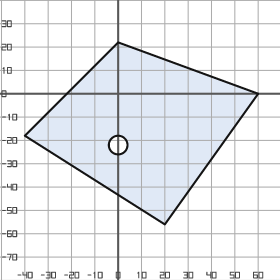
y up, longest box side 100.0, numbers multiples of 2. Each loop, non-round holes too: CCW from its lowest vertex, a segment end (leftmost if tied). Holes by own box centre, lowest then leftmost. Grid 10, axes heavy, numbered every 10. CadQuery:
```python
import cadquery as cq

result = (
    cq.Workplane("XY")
    .moveTo(20.0, -56.0)
    .lineTo(60.0, 0.0)
    .lineTo(0.0, 22.0)
    .lineTo(-40.0, -18.0)
    .close()
    .moveTo(0.0, -22.0)
    .circle(4.0)
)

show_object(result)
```